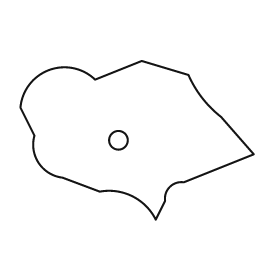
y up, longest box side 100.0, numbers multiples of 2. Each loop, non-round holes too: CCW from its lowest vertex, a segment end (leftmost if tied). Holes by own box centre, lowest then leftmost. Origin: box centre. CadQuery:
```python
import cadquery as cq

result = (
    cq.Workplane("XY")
    .moveTo(8.0, -34.0)
    .lineTo(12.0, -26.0)
    .threePointArc((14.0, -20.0), (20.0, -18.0))
    .lineTo(50.0, -6.0)
    .lineTo(36.0, 10.0)
    .threePointArc((28.0, 18.0), (22.0, 28.0))
    .lineTo(2.0, 34.0)
    .lineTo(-18.0, 26.0)
    .threePointArc((-38.0, 30.0), (-50.0, 14.0))
    .lineTo(-44.0, 2.0)
    .threePointArc((-42.0, -10.0), (-32.0, -16.0))
    .lineTo(-16.0, -22.0)
    .threePointArc((-2.0, -24.0), (8.0, -34.0))
    .close()
    .moveTo(-8.0, 0.0)
    .circle(4.0)
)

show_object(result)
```